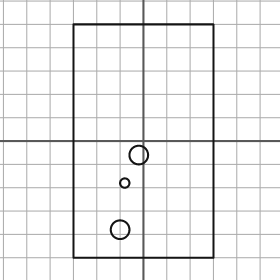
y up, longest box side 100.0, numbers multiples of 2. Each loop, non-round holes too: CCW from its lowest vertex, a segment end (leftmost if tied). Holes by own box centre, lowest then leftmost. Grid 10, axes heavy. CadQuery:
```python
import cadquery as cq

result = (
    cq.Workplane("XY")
    .moveTo(-30.0, -50.0)
    .lineTo(30.0, -50.0)
    .lineTo(30.0, 50.0)
    .lineTo(-30.0, 50.0)
    .close()
    .moveTo(-10.0, -38.0)
    .circle(4.0)
    .moveTo(-8.0, -18.0)
    .circle(2.0)
    .moveTo(-2.0, -6.0)
    .circle(4.0)
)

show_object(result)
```